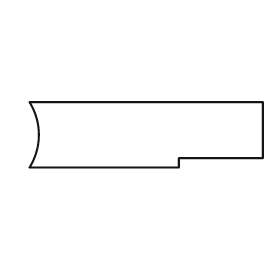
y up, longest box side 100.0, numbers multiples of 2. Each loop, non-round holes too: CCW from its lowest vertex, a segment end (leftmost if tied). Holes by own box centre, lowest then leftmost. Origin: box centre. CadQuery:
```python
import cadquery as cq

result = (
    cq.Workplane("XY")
    .moveTo(-50.0, -14.0)
    .lineTo(14.0, -14.0)
    .lineTo(14.0, -10.0)
    .lineTo(50.0, -10.0)
    .lineTo(50.0, 14.0)
    .lineTo(-50.0, 14.0)
    .threePointArc((-46.0, 0.0), (-50.0, -14.0))
    .close()
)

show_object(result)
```